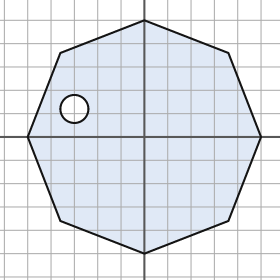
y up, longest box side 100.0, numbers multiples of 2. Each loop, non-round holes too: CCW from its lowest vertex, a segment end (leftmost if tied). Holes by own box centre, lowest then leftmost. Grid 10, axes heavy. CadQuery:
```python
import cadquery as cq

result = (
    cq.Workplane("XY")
    .moveTo(0.0, -50.0)
    .lineTo(36.0, -36.0)
    .lineTo(50.0, 0.0)
    .lineTo(36.0, 36.0)
    .lineTo(0.0, 50.0)
    .lineTo(-36.0, 36.0)
    .lineTo(-50.0, 0.0)
    .lineTo(-36.0, -36.0)
    .close()
    .moveTo(-30.0, 12.0)
    .circle(6.0)
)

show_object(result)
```